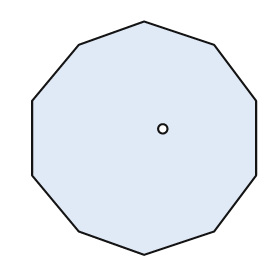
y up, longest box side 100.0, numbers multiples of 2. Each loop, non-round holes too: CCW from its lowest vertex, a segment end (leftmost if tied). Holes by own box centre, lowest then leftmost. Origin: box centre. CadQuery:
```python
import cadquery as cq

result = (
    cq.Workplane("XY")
    .moveTo(0.0, -50.0)
    .lineTo(30.0, -40.0)
    .lineTo(48.0, -16.0)
    .lineTo(48.0, 16.0)
    .lineTo(30.0, 40.0)
    .lineTo(0.0, 50.0)
    .lineTo(-28.0, 40.0)
    .lineTo(-48.0, 16.0)
    .lineTo(-48.0, -16.0)
    .lineTo(-28.0, -40.0)
    .close()
    .moveTo(8.0, 4.0)
    .circle(2.0)
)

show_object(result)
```